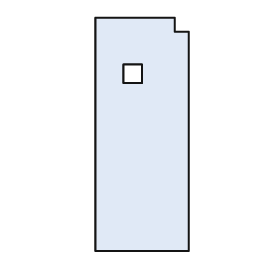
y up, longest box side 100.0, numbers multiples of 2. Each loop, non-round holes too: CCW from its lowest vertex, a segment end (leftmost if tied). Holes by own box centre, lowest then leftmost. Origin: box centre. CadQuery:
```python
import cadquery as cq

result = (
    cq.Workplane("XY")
    .moveTo(-20.0, -50.0)
    .lineTo(20.0, -50.0)
    .lineTo(20.0, 44.0)
    .lineTo(14.0, 44.0)
    .lineTo(14.0, 50.0)
    .lineTo(-20.0, 50.0)
    .close()
    .moveTo(-8.0, 22.0)
    .lineTo(0.0, 22.0)
    .lineTo(0.0, 30.0)
    .lineTo(-8.0, 30.0)
    .close()
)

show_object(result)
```